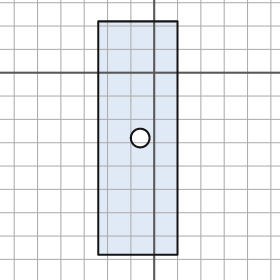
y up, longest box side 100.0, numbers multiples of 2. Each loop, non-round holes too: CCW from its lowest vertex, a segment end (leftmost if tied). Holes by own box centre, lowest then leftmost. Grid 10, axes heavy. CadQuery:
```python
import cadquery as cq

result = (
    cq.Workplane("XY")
    .moveTo(-24.0, -78.0)
    .lineTo(10.0, -78.0)
    .lineTo(10.0, 22.0)
    .lineTo(-24.0, 22.0)
    .close()
    .moveTo(-6.0, -28.0)
    .circle(4.0)
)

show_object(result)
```